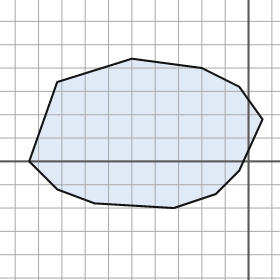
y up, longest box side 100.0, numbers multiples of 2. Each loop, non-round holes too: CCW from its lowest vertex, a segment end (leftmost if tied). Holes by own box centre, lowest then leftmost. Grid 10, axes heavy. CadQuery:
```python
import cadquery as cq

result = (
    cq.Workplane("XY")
    .moveTo(-32.0, -20.0)
    .lineTo(-14.0, -14.0)
    .lineTo(-4.0, -4.0)
    .lineTo(6.0, 18.0)
    .lineTo(-4.0, 32.0)
    .lineTo(-20.0, 40.0)
    .lineTo(-50.0, 44.0)
    .lineTo(-82.0, 34.0)
    .lineTo(-94.0, 0.0)
    .lineTo(-82.0, -12.0)
    .lineTo(-66.0, -18.0)
    .close()
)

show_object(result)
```